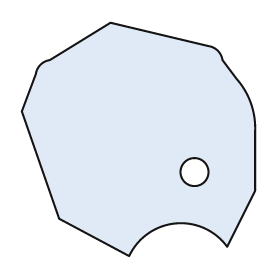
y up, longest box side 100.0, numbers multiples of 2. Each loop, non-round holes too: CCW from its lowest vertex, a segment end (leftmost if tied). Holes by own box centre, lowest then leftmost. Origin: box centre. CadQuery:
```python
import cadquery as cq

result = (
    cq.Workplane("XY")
    .moveTo(-4.0, -50.0)
    .threePointArc((16.0, -36.0), (38.0, -46.0))
    .lineTo(50.0, -22.0)
    .lineTo(50.0, 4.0)
    .threePointArc((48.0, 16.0), (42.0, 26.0))
    .lineTo(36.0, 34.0)
    .threePointArc((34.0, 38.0), (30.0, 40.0))
    .lineTo(-12.0, 50.0)
    .lineTo(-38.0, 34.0)
    .threePointArc((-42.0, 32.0), (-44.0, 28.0))
    .lineTo(-50.0, 12.0)
    .lineTo(-34.0, -34.0)
    .close()
    .moveTo(24.0, -14.0)
    .circle(6.0)
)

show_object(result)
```